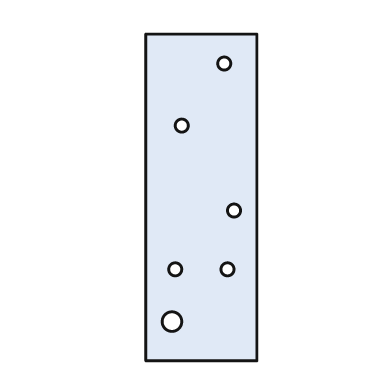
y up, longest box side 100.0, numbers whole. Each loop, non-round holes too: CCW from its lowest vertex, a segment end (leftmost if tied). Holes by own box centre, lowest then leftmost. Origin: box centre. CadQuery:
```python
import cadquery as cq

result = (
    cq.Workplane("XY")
    .moveTo(-17.0, -50.0)
    .lineTo(17.0, -50.0)
    .lineTo(17.0, 50.0)
    .lineTo(-17.0, 50.0)
    .close()
    .moveTo(-9.0, -38.0)
    .circle(3.0)
    .moveTo(-8.0, -22.0)
    .circle(2.0)
    .moveTo(8.0, -22.0)
    .circle(2.0)
    .moveTo(10.0, -4.0)
    .circle(2.0)
    .moveTo(-6.0, 22.0)
    .circle(2.0)
    .moveTo(7.0, 41.0)
    .circle(2.0)
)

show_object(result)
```